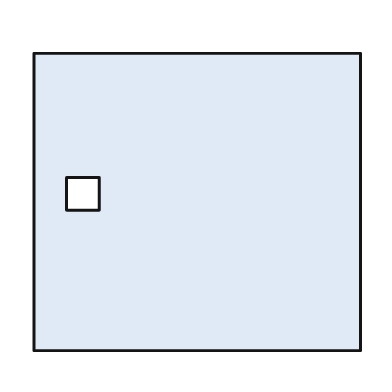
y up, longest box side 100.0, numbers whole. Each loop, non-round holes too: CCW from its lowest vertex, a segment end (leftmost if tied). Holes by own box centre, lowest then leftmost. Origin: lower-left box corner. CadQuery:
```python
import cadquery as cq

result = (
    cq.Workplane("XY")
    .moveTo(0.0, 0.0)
    .lineTo(100.0, 0.0)
    .lineTo(100.0, 91.0)
    .lineTo(0.0, 91.0)
    .close()
    .moveTo(10.0, 43.0)
    .lineTo(20.0, 43.0)
    .lineTo(20.0, 53.0)
    .lineTo(10.0, 53.0)
    .close()
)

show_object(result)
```